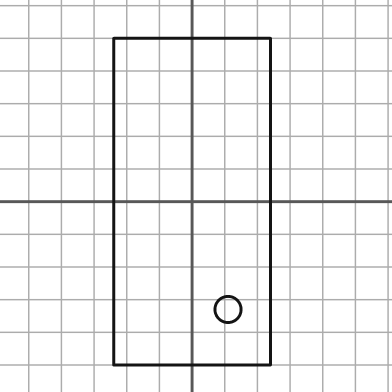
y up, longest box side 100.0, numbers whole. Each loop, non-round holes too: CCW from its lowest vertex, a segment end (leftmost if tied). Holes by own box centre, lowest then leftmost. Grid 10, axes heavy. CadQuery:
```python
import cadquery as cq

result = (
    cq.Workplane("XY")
    .moveTo(-24.0, -50.0)
    .lineTo(24.0, -50.0)
    .lineTo(24.0, 50.0)
    .lineTo(-24.0, 50.0)
    .close()
    .moveTo(11.0, -33.0)
    .circle(4.0)
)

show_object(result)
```